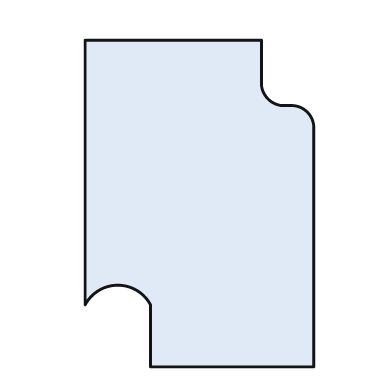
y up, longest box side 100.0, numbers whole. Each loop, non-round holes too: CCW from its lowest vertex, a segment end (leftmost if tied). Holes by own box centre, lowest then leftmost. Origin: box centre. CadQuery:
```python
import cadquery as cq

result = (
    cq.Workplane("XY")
    .moveTo(-15.0, -50.0)
    .lineTo(35.0, -50.0)
    .lineTo(35.0, 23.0)
    .threePointArc((33.0, 28.0), (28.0, 30.0))
    .lineTo(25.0, 30.0)
    .threePointArc((21.0, 32.0), (19.0, 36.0))
    .lineTo(19.0, 50.0)
    .lineTo(-35.0, 50.0)
    .lineTo(-35.0, -31.0)
    .threePointArc((-25.0, -25.0), (-15.0, -31.0))
    .close()
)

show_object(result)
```